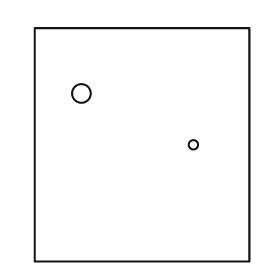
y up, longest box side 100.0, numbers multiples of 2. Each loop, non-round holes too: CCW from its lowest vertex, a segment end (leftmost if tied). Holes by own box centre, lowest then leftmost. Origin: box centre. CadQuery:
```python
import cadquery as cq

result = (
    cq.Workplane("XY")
    .moveTo(-46.0, -50.0)
    .lineTo(46.0, -50.0)
    .lineTo(46.0, 50.0)
    .lineTo(-46.0, 50.0)
    .close()
    .moveTo(22.0, 0.0)
    .circle(2.0)
    .moveTo(-26.0, 22.0)
    .circle(4.0)
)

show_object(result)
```